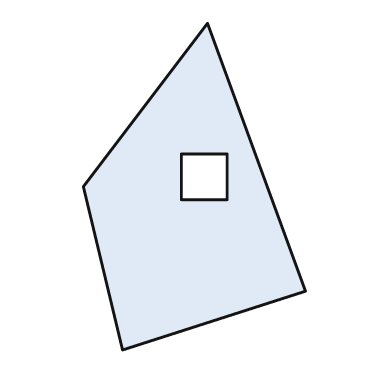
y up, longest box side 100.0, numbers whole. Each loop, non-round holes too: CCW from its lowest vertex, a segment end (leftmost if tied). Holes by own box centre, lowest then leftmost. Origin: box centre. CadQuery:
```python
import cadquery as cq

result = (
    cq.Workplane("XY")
    .moveTo(-22.0, -50.0)
    .lineTo(34.0, -32.0)
    .lineTo(4.0, 50.0)
    .lineTo(-34.0, 0.0)
    .close()
    .moveTo(-4.0, -4.0)
    .lineTo(10.0, -4.0)
    .lineTo(10.0, 10.0)
    .lineTo(-4.0, 10.0)
    .close()
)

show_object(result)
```